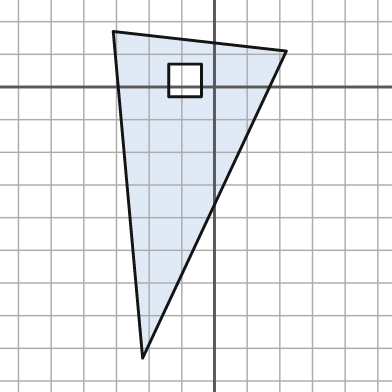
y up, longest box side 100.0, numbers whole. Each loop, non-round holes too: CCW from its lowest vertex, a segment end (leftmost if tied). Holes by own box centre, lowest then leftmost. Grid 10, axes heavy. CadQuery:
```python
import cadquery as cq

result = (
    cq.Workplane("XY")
    .moveTo(-22.0, -83.0)
    .lineTo(22.0, 11.0)
    .lineTo(-31.0, 17.0)
    .close()
    .moveTo(-14.0, -3.0)
    .lineTo(-4.0, -3.0)
    .lineTo(-4.0, 7.0)
    .lineTo(-14.0, 7.0)
    .close()
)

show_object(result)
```